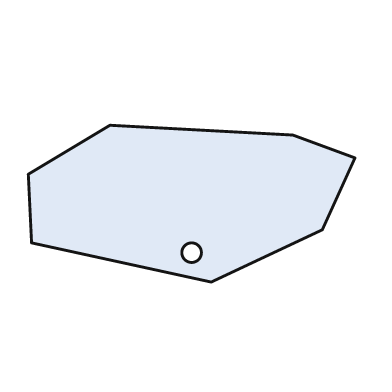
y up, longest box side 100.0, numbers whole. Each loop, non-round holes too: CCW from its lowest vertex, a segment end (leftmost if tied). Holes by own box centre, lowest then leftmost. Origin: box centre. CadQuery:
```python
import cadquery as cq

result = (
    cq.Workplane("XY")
    .moveTo(6.0, -24.0)
    .lineTo(40.0, -8.0)
    .lineTo(50.0, 14.0)
    .lineTo(31.0, 21.0)
    .lineTo(-25.0, 24.0)
    .lineTo(-50.0, 9.0)
    .lineTo(-49.0, -12.0)
    .close()
    .moveTo(0.0, -15.0)
    .circle(3.0)
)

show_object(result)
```